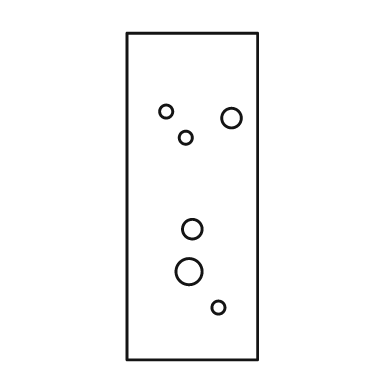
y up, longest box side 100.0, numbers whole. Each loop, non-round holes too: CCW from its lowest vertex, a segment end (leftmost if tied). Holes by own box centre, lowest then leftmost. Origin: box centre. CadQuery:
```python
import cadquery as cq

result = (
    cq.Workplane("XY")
    .moveTo(-20.0, -50.0)
    .lineTo(20.0, -50.0)
    .lineTo(20.0, 50.0)
    .lineTo(-20.0, 50.0)
    .close()
    .moveTo(8.0, -34.0)
    .circle(2.0)
    .moveTo(-1.0, -23.0)
    .circle(4.0)
    .moveTo(0.0, -10.0)
    .circle(3.0)
    .moveTo(-2.0, 18.0)
    .circle(2.0)
    .moveTo(12.0, 24.0)
    .circle(3.0)
    .moveTo(-8.0, 26.0)
    .circle(2.0)
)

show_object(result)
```